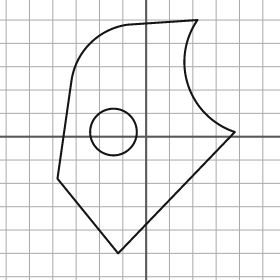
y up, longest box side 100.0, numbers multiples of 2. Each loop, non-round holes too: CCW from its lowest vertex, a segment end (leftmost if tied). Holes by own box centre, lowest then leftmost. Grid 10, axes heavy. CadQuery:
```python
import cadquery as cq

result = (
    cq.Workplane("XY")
    .moveTo(-12.0, -50.0)
    .lineTo(38.0, 2.0)
    .threePointArc((18.0, 22.0), (22.0, 50.0))
    .lineTo(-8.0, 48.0)
    .threePointArc((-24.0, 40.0), (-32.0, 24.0))
    .lineTo(-38.0, -18.0)
    .close()
    .moveTo(-14.0, 2.0)
    .circle(10.0)
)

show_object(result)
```